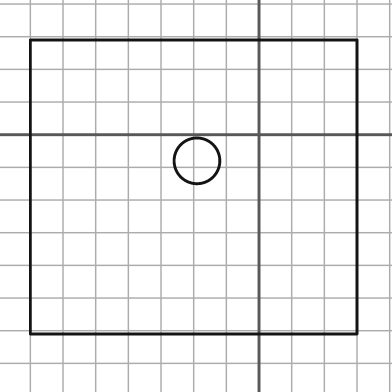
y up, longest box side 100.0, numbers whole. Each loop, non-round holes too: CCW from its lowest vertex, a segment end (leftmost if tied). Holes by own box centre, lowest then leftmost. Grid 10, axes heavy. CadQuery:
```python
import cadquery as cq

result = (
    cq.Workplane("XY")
    .moveTo(-70.0, -61.0)
    .lineTo(30.0, -61.0)
    .lineTo(30.0, 29.0)
    .lineTo(-70.0, 29.0)
    .close()
    .moveTo(-19.0, -8.0)
    .circle(7.0)
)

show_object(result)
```